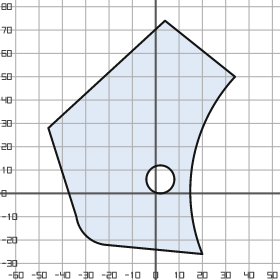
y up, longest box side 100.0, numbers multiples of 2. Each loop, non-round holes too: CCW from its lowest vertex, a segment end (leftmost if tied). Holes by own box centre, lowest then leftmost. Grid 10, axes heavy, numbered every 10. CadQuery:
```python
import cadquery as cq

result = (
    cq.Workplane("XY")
    .moveTo(20.0, -26.0)
    .threePointArc((16.0, 14.0), (34.0, 50.0))
    .lineTo(4.0, 74.0)
    .lineTo(-46.0, 28.0)
    .lineTo(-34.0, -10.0)
    .threePointArc((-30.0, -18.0), (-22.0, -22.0))
    .close()
    .moveTo(2.0, 6.0)
    .circle(6.0)
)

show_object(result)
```